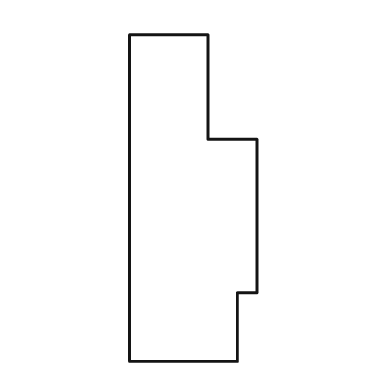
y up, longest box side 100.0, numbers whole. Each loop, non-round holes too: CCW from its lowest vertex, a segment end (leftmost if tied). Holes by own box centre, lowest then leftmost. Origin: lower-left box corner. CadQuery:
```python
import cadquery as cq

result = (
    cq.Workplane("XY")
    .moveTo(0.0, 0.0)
    .lineTo(33.0, 0.0)
    .lineTo(33.0, 21.0)
    .lineTo(39.0, 21.0)
    .lineTo(39.0, 68.0)
    .lineTo(24.0, 68.0)
    .lineTo(24.0, 100.0)
    .lineTo(0.0, 100.0)
    .close()
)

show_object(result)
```